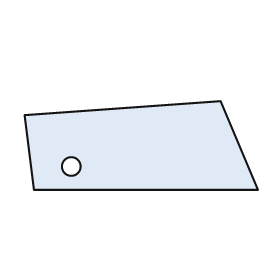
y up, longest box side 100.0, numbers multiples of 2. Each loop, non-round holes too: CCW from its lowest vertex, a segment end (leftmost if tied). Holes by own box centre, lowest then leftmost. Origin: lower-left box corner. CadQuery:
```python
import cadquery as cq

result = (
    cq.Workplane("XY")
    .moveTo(4.0, 0.0)
    .lineTo(100.0, 0.0)
    .lineTo(84.0, 38.0)
    .lineTo(0.0, 32.0)
    .close()
    .moveTo(20.0, 10.0)
    .circle(4.0)
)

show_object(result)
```